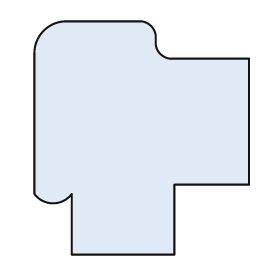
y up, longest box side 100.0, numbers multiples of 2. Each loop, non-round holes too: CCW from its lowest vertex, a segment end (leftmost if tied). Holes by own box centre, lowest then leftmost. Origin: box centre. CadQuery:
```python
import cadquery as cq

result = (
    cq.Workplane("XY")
    .moveTo(-30.0, -50.0)
    .lineTo(14.0, -50.0)
    .lineTo(14.0, -20.0)
    .lineTo(46.0, -20.0)
    .lineTo(46.0, 34.0)
    .lineTo(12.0, 34.0)
    .threePointArc((8.0, 36.0), (6.0, 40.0))
    .lineTo(6.0, 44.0)
    .threePointArc((4.0, 48.0), (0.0, 50.0))
    .lineTo(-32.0, 50.0)
    .threePointArc((-42.0, 46.0), (-46.0, 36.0))
    .lineTo(-46.0, -24.0)
    .threePointArc((-38.0, -28.0), (-30.0, -24.0))
    .close()
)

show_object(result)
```